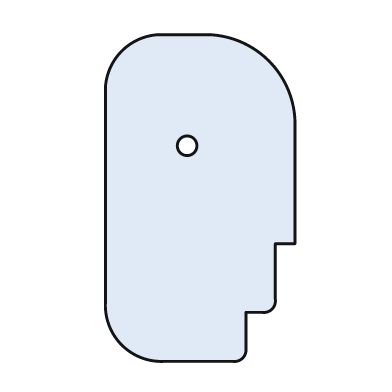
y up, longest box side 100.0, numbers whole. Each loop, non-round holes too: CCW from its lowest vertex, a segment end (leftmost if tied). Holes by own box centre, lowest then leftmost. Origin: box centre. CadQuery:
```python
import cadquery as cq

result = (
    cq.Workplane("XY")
    .moveTo(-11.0, -50.0)
    .lineTo(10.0, -50.0)
    .threePointArc((13.0, -49.0), (14.0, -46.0))
    .lineTo(14.0, -35.0)
    .lineTo(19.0, -35.0)
    .threePointArc((22.0, -34.0), (23.0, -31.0))
    .lineTo(23.0, -14.0)
    .lineTo(29.0, -14.0)
    .lineTo(29.0, 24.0)
    .threePointArc((21.0, 42.0), (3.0, 50.0))
    .lineTo(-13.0, 50.0)
    .threePointArc((-24.0, 45.0), (-29.0, 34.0))
    .lineTo(-29.0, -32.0)
    .threePointArc((-24.0, -45.0), (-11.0, -50.0))
    .close()
    .moveTo(-4.0, 16.0)
    .circle(3.0)
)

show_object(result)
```